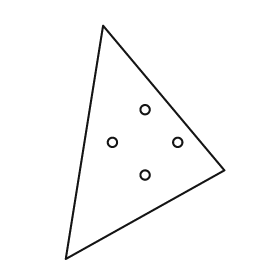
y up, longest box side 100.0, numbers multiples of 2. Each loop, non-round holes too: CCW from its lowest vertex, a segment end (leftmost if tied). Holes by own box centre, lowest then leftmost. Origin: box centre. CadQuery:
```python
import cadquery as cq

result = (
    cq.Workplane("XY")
    .moveTo(-34.0, -50.0)
    .lineTo(34.0, -12.0)
    .lineTo(-18.0, 50.0)
    .close()
    .moveTo(0.0, -14.0)
    .circle(2.0)
    .moveTo(-14.0, 0.0)
    .circle(2.0)
    .moveTo(14.0, 0.0)
    .circle(2.0)
    .moveTo(0.0, 14.0)
    .circle(2.0)
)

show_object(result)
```